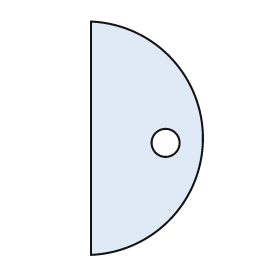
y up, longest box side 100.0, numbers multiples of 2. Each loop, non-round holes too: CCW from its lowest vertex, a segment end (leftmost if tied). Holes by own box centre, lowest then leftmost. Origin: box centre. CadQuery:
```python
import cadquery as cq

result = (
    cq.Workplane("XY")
    .moveTo(-24.0, -50.0)
    .threePointArc((24.0, 0.0), (-24.0, 50.0))
    .close()
    .moveTo(8.0, -2.0)
    .circle(6.0)
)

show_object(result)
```